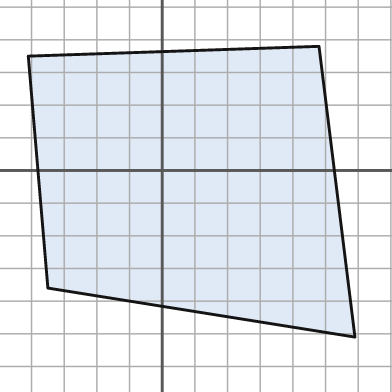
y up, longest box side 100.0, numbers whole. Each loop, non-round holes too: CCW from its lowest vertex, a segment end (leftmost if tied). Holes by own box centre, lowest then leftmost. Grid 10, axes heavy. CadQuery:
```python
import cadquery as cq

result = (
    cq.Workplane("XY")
    .moveTo(59.0, -51.0)
    .lineTo(48.0, 38.0)
    .lineTo(-41.0, 35.0)
    .lineTo(-35.0, -36.0)
    .close()
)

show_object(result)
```